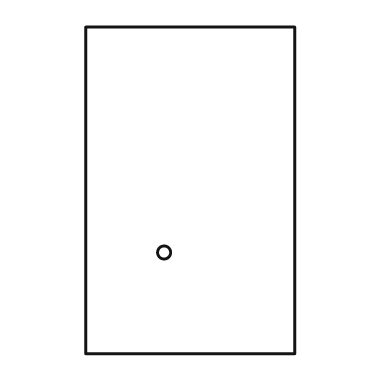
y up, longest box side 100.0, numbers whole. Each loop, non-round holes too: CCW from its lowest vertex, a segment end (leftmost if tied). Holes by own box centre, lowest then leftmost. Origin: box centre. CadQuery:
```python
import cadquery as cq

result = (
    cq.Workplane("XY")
    .moveTo(-32.0, -50.0)
    .lineTo(32.0, -50.0)
    .lineTo(32.0, 50.0)
    .lineTo(-32.0, 50.0)
    .close()
    .moveTo(-8.0, -19.0)
    .circle(2.0)
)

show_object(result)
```